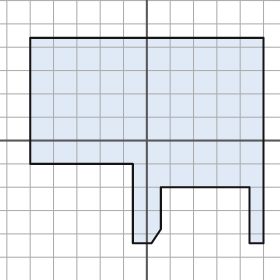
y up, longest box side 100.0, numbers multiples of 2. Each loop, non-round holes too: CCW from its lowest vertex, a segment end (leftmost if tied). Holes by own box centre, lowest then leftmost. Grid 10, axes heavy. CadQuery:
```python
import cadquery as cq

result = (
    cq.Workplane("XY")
    .moveTo(-6.0, -44.0)
    .lineTo(2.0, -44.0)
    .lineTo(6.0, -38.0)
    .lineTo(6.0, -20.0)
    .lineTo(44.0, -20.0)
    .lineTo(44.0, -44.0)
    .lineTo(50.0, -44.0)
    .lineTo(50.0, 44.0)
    .lineTo(-50.0, 44.0)
    .lineTo(-50.0, -10.0)
    .lineTo(-6.0, -10.0)
    .close()
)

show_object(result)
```